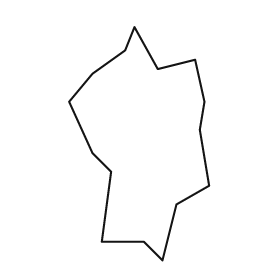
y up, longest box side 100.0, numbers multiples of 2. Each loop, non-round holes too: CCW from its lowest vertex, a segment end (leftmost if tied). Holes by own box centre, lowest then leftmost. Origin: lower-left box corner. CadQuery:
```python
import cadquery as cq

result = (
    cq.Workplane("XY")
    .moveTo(40.0, 0.0)
    .lineTo(46.0, 24.0)
    .lineTo(60.0, 32.0)
    .lineTo(56.0, 56.0)
    .lineTo(58.0, 68.0)
    .lineTo(54.0, 86.0)
    .lineTo(38.0, 82.0)
    .lineTo(28.0, 100.0)
    .lineTo(24.0, 90.0)
    .lineTo(10.0, 80.0)
    .lineTo(0.0, 68.0)
    .lineTo(10.0, 46.0)
    .lineTo(18.0, 38.0)
    .lineTo(14.0, 8.0)
    .lineTo(32.0, 8.0)
    .close()
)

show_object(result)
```